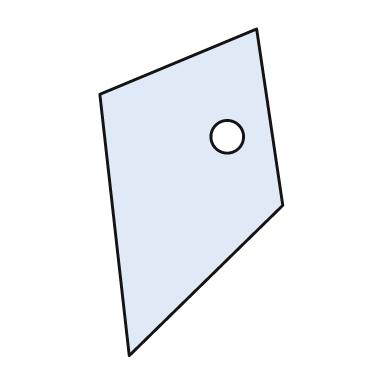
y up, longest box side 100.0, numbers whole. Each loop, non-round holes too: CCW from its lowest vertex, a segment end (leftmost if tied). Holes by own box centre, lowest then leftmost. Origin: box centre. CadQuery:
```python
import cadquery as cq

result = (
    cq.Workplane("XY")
    .moveTo(-19.0, -50.0)
    .lineTo(28.0, -4.0)
    .lineTo(20.0, 50.0)
    .lineTo(-28.0, 30.0)
    .close()
    .moveTo(11.0, 17.0)
    .circle(5.0)
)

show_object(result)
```